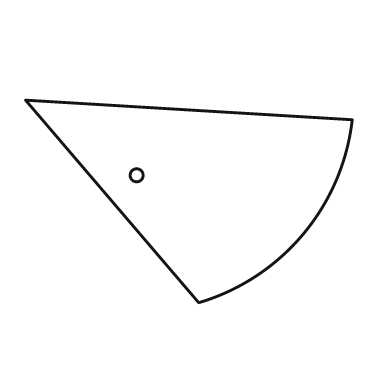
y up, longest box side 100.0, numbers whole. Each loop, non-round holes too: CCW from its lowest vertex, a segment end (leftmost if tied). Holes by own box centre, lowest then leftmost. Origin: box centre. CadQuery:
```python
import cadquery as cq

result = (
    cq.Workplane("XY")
    .moveTo(3.0, -31.0)
    .threePointArc((35.0, -10.0), (50.0, 25.0))
    .lineTo(-50.0, 31.0)
    .close()
    .moveTo(-16.0, 8.0)
    .circle(2.0)
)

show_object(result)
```